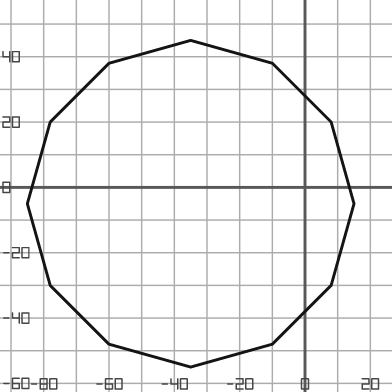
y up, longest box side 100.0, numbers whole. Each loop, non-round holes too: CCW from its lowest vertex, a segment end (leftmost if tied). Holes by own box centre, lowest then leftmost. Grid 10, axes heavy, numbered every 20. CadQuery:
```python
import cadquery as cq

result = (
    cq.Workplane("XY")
    .moveTo(-35.0, -55.0)
    .lineTo(-10.0, -48.0)
    .lineTo(8.0, -30.0)
    .lineTo(15.0, -5.0)
    .lineTo(8.0, 20.0)
    .lineTo(-10.0, 38.0)
    .lineTo(-35.0, 45.0)
    .lineTo(-60.0, 38.0)
    .lineTo(-78.0, 20.0)
    .lineTo(-85.0, -5.0)
    .lineTo(-78.0, -30.0)
    .lineTo(-60.0, -48.0)
    .close()
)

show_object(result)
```